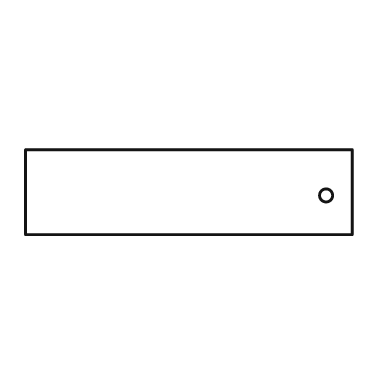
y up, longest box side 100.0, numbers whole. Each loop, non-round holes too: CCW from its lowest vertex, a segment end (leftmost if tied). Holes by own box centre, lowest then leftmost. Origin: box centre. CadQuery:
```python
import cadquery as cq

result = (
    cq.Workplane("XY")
    .moveTo(-50.0, -13.0)
    .lineTo(50.0, -13.0)
    .lineTo(50.0, 13.0)
    .lineTo(-50.0, 13.0)
    .close()
    .moveTo(42.0, -1.0)
    .circle(2.0)
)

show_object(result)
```